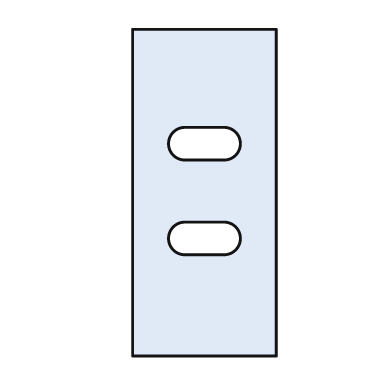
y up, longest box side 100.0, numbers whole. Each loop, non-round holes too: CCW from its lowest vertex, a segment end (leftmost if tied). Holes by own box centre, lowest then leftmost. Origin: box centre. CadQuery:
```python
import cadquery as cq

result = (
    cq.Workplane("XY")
    .moveTo(-22.0, -50.0)
    .lineTo(22.0, -50.0)
    .lineTo(22.0, 50.0)
    .lineTo(-22.0, 50.0)
    .close()
    .moveTo(-6.0, -19.0)
    .lineTo(6.0, -19.0)
    .threePointArc((11.0, -14.0), (6.0, -9.0))
    .lineTo(-6.0, -9.0)
    .threePointArc((-11.0, -14.0), (-6.0, -19.0))
    .close()
    .moveTo(-6.0, 10.0)
    .lineTo(6.0, 10.0)
    .threePointArc((11.0, 15.0), (6.0, 20.0))
    .lineTo(-6.0, 20.0)
    .threePointArc((-11.0, 15.0), (-6.0, 10.0))
    .close()
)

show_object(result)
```